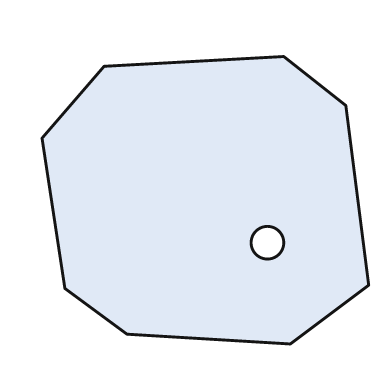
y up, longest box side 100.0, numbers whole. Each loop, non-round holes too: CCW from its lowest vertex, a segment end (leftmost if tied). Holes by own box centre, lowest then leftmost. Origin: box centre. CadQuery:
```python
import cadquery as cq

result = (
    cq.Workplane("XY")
    .moveTo(26.0, -44.0)
    .lineTo(50.0, -26.0)
    .lineTo(43.0, 29.0)
    .lineTo(24.0, 44.0)
    .lineTo(-31.0, 41.0)
    .lineTo(-50.0, 19.0)
    .lineTo(-43.0, -27.0)
    .lineTo(-24.0, -41.0)
    .close()
    .moveTo(19.0, -13.0)
    .circle(5.0)
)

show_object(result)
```